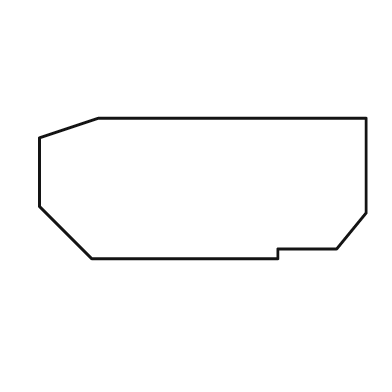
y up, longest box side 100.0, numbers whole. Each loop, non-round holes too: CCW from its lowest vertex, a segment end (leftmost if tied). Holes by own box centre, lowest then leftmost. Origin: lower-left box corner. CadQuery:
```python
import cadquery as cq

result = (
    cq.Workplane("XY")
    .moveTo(16.0, 0.0)
    .lineTo(73.0, 0.0)
    .lineTo(73.0, 3.0)
    .lineTo(91.0, 3.0)
    .lineTo(100.0, 14.0)
    .lineTo(100.0, 43.0)
    .lineTo(18.0, 43.0)
    .lineTo(0.0, 37.0)
    .lineTo(0.0, 16.0)
    .close()
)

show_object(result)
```